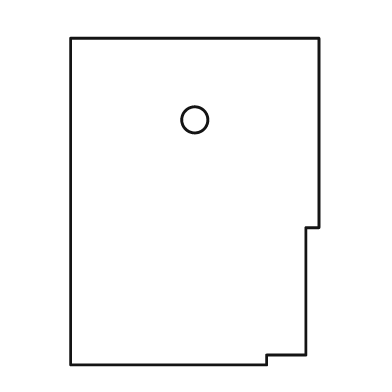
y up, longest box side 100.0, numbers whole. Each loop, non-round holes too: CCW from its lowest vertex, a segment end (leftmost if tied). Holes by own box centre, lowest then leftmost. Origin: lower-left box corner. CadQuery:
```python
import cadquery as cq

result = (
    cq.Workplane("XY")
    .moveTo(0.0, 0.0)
    .lineTo(60.0, 0.0)
    .lineTo(60.0, 3.0)
    .lineTo(72.0, 3.0)
    .lineTo(72.0, 42.0)
    .lineTo(76.0, 42.0)
    .lineTo(76.0, 100.0)
    .lineTo(0.0, 100.0)
    .close()
    .moveTo(38.0, 75.0)
    .circle(4.0)
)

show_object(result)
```